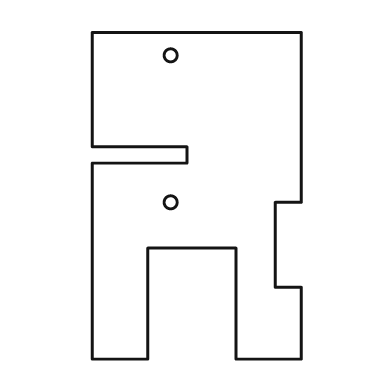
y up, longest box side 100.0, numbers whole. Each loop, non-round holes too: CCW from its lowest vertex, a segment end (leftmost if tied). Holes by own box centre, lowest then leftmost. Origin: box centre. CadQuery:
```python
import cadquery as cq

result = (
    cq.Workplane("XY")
    .moveTo(-32.0, -50.0)
    .lineTo(-15.0, -50.0)
    .lineTo(-15.0, -16.0)
    .lineTo(12.0, -16.0)
    .lineTo(12.0, -50.0)
    .lineTo(32.0, -50.0)
    .lineTo(32.0, -28.0)
    .lineTo(24.0, -28.0)
    .lineTo(24.0, -2.0)
    .lineTo(32.0, -2.0)
    .lineTo(32.0, 50.0)
    .lineTo(-32.0, 50.0)
    .lineTo(-32.0, 15.0)
    .lineTo(-3.0, 15.0)
    .lineTo(-3.0, 10.0)
    .lineTo(-32.0, 10.0)
    .close()
    .moveTo(-8.0, -2.0)
    .circle(2.0)
    .moveTo(-8.0, 43.0)
    .circle(2.0)
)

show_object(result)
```